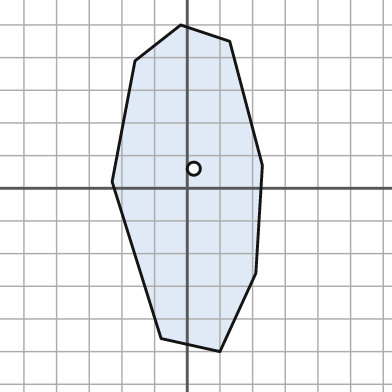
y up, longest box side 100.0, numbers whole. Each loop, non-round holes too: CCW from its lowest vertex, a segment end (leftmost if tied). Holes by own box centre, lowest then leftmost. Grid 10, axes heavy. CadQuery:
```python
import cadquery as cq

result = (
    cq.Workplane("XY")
    .moveTo(10.0, -50.0)
    .lineTo(21.0, -26.0)
    .lineTo(23.0, 7.0)
    .lineTo(13.0, 45.0)
    .lineTo(-2.0, 50.0)
    .lineTo(-16.0, 39.0)
    .lineTo(-23.0, 2.0)
    .lineTo(-8.0, -46.0)
    .close()
    .moveTo(2.0, 6.0)
    .circle(2.0)
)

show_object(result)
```